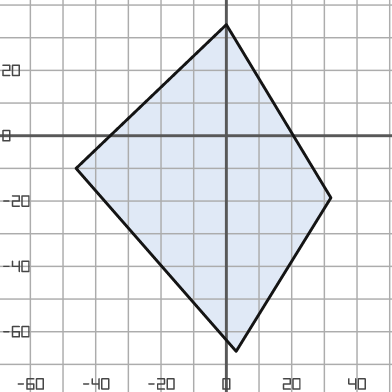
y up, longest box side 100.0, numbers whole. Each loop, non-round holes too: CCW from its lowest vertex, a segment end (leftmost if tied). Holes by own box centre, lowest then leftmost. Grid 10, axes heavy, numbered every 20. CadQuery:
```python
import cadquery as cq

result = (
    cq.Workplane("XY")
    .moveTo(3.0, -66.0)
    .lineTo(32.0, -19.0)
    .lineTo(0.0, 34.0)
    .lineTo(-46.0, -10.0)
    .close()
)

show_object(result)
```